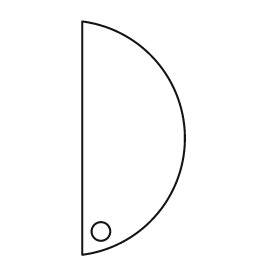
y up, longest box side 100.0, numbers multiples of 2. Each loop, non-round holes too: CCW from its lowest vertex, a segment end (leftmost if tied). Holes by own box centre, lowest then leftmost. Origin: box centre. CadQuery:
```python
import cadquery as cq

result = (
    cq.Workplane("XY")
    .moveTo(-22.0, -50.0)
    .threePointArc((22.0, 0.0), (-22.0, 50.0))
    .close()
    .moveTo(-14.0, -40.0)
    .circle(4.0)
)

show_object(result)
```